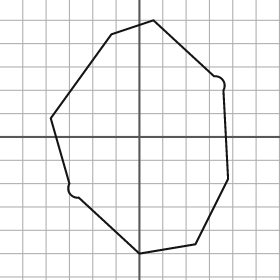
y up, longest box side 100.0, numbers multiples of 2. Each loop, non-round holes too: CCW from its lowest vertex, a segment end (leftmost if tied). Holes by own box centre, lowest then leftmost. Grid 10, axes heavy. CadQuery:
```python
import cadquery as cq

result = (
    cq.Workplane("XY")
    .moveTo(0.0, -50.0)
    .lineTo(24.0, -46.0)
    .lineTo(38.0, -18.0)
    .lineTo(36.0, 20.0)
    .threePointArc((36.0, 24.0), (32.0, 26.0))
    .lineTo(6.0, 50.0)
    .lineTo(-12.0, 44.0)
    .lineTo(-38.0, 8.0)
    .lineTo(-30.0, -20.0)
    .threePointArc((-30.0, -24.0), (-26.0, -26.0))
    .close()
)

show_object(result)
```